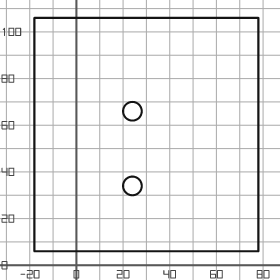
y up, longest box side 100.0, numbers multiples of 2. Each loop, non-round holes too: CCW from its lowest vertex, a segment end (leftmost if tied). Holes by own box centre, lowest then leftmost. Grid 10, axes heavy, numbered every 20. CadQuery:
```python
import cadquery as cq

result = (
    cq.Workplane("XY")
    .moveTo(-18.0, 6.0)
    .lineTo(78.0, 6.0)
    .lineTo(78.0, 106.0)
    .lineTo(-18.0, 106.0)
    .close()
    .moveTo(24.0, 34.0)
    .circle(4.0)
    .moveTo(24.0, 66.0)
    .circle(4.0)
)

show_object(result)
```